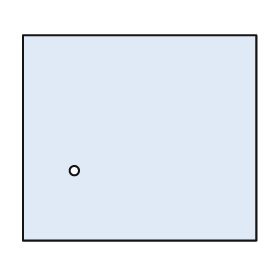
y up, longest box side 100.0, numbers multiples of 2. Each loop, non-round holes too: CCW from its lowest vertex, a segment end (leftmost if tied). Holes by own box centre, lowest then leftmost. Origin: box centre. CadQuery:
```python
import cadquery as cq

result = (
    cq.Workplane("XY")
    .moveTo(-50.0, -44.0)
    .lineTo(50.0, -44.0)
    .lineTo(50.0, 44.0)
    .lineTo(-50.0, 44.0)
    .close()
    .moveTo(-28.0, -14.0)
    .circle(2.0)
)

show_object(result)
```